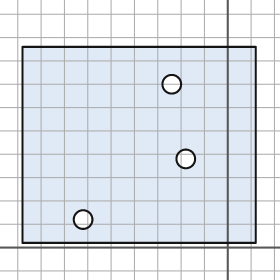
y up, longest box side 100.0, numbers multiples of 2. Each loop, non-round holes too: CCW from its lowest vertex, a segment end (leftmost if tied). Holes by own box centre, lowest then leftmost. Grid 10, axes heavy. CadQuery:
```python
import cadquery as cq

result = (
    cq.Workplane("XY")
    .moveTo(-88.0, 2.0)
    .lineTo(12.0, 2.0)
    .lineTo(12.0, 86.0)
    .lineTo(-88.0, 86.0)
    .close()
    .moveTo(-62.0, 12.0)
    .circle(4.0)
    .moveTo(-18.0, 38.0)
    .circle(4.0)
    .moveTo(-24.0, 70.0)
    .circle(4.0)
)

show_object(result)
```